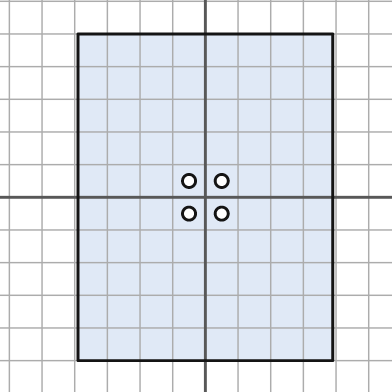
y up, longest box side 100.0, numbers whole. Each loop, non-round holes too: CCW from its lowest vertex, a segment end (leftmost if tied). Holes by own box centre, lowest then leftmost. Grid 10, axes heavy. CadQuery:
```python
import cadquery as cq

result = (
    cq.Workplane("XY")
    .moveTo(-39.0, -50.0)
    .lineTo(39.0, -50.0)
    .lineTo(39.0, 50.0)
    .lineTo(-39.0, 50.0)
    .close()
    .moveTo(-5.0, -5.0)
    .circle(2.0)
    .moveTo(5.0, -5.0)
    .circle(2.0)
    .moveTo(-5.0, 5.0)
    .circle(2.0)
    .moveTo(5.0, 5.0)
    .circle(2.0)
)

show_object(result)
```